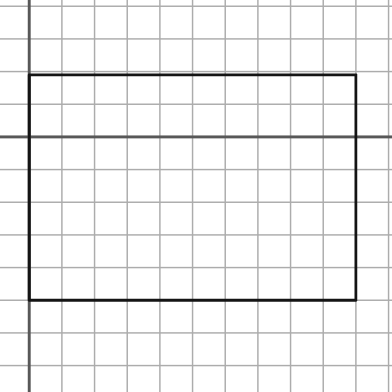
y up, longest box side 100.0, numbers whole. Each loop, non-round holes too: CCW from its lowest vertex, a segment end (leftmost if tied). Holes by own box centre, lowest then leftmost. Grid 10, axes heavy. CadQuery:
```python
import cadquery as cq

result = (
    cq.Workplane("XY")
    .moveTo(0.0, -50.0)
    .lineTo(100.0, -50.0)
    .lineTo(100.0, 19.0)
    .lineTo(0.0, 19.0)
    .close()
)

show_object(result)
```